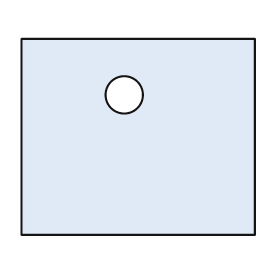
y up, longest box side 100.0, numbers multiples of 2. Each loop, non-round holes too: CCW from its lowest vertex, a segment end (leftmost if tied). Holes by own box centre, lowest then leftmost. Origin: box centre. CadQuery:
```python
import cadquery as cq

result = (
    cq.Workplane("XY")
    .moveTo(-50.0, -42.0)
    .lineTo(50.0, -42.0)
    .lineTo(50.0, 42.0)
    .lineTo(-50.0, 42.0)
    .close()
    .moveTo(-6.0, 18.0)
    .circle(8.0)
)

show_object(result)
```